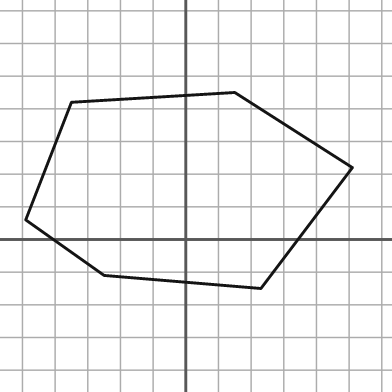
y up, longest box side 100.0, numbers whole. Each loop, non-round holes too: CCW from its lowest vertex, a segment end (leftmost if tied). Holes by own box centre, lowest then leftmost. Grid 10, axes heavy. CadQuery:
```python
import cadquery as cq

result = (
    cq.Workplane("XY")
    .moveTo(23.0, -15.0)
    .lineTo(51.0, 22.0)
    .lineTo(15.0, 45.0)
    .lineTo(-35.0, 42.0)
    .lineTo(-49.0, 6.0)
    .lineTo(-25.0, -11.0)
    .close()
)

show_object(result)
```